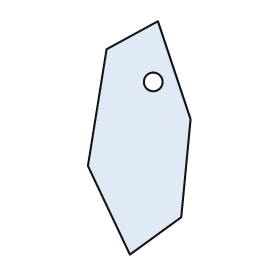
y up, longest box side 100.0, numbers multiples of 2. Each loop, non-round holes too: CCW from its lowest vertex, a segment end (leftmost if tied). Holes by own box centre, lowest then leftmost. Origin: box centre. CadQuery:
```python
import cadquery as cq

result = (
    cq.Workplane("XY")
    .moveTo(-4.0, -50.0)
    .lineTo(18.0, -34.0)
    .lineTo(22.0, 8.0)
    .lineTo(8.0, 50.0)
    .lineTo(-14.0, 38.0)
    .lineTo(-22.0, -12.0)
    .close()
    .moveTo(6.0, 24.0)
    .circle(4.0)
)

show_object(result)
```